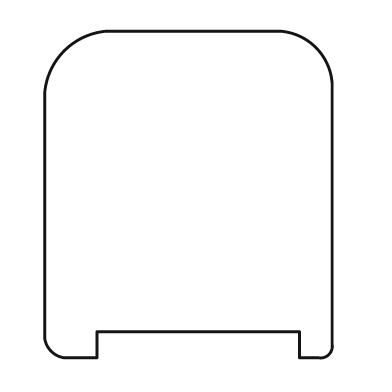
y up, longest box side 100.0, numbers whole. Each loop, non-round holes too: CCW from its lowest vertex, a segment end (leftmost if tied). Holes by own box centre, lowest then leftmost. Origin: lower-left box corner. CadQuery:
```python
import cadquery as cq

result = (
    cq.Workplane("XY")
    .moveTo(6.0, 0.0)
    .lineTo(16.0, 0.0)
    .lineTo(16.0, 8.0)
    .lineTo(78.0, 8.0)
    .lineTo(78.0, 0.0)
    .lineTo(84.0, 0.0)
    .threePointArc((87.0, 1.0), (88.0, 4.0))
    .lineTo(88.0, 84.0)
    .threePointArc((83.0, 95.0), (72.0, 100.0))
    .lineTo(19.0, 100.0)
    .threePointArc((6.0, 94.0), (0.0, 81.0))
    .lineTo(0.0, 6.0)
    .threePointArc((2.0, 2.0), (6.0, 0.0))
    .close()
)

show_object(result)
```